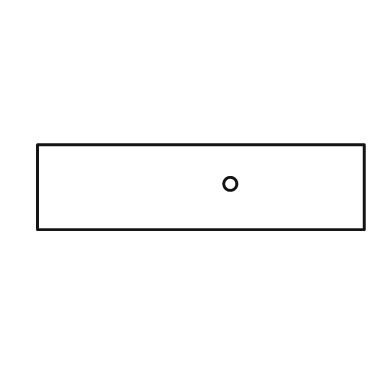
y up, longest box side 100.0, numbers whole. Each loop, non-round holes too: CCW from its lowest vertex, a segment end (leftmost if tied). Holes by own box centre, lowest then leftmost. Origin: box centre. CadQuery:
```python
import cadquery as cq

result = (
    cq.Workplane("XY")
    .moveTo(-50.0, -13.0)
    .lineTo(50.0, -13.0)
    .lineTo(50.0, 13.0)
    .lineTo(-50.0, 13.0)
    .close()
    .moveTo(9.0, 1.0)
    .circle(2.0)
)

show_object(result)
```